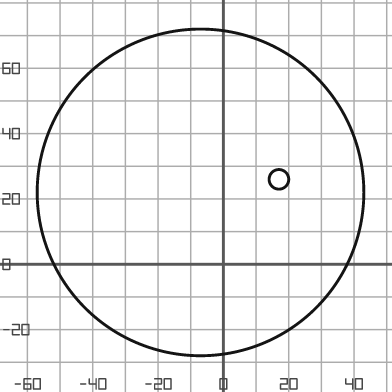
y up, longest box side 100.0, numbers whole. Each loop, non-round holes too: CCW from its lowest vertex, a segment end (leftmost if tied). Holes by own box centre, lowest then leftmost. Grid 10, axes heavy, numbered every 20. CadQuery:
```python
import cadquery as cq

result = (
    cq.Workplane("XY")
    .moveTo(-7.0, 22.0)
    .circle(50.0)
    .moveTo(17.0, 26.0)
    .circle(3.0)
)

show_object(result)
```